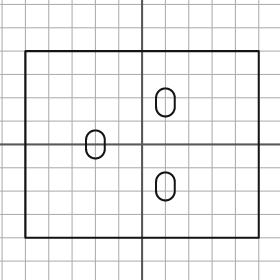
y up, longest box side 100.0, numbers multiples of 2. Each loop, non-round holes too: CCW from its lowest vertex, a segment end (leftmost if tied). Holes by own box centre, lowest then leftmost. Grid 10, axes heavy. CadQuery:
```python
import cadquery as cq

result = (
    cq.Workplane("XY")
    .moveTo(-50.0, -40.0)
    .lineTo(50.0, -40.0)
    .lineTo(50.0, 40.0)
    .lineTo(-50.0, 40.0)
    .close()
    .moveTo(6.0, -20.0)
    .threePointArc((10.0, -24.0), (14.0, -20.0))
    .lineTo(14.0, -16.0)
    .threePointArc((10.0, -12.0), (6.0, -16.0))
    .close()
    .moveTo(-24.0, -2.0)
    .threePointArc((-20.0, -6.0), (-16.0, -2.0))
    .lineTo(-16.0, 2.0)
    .threePointArc((-20.0, 6.0), (-24.0, 2.0))
    .close()
    .moveTo(6.0, 16.0)
    .threePointArc((10.0, 12.0), (14.0, 16.0))
    .lineTo(14.0, 20.0)
    .threePointArc((10.0, 24.0), (6.0, 20.0))
    .close()
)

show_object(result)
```